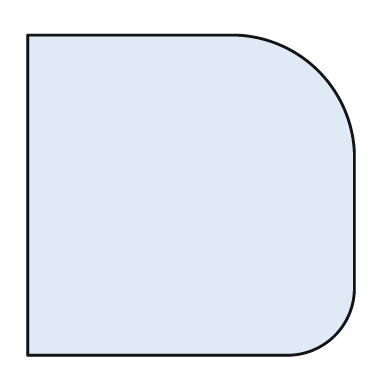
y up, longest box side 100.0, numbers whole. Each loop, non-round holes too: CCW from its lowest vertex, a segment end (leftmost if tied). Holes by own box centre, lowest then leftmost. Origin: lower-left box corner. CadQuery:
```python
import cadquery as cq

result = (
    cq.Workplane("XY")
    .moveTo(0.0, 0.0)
    .lineTo(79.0, 0.0)
    .threePointArc((94.0, 6.0), (100.0, 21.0))
    .lineTo(100.0, 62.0)
    .threePointArc((89.0, 87.0), (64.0, 98.0))
    .lineTo(0.0, 98.0)
    .close()
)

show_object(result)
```